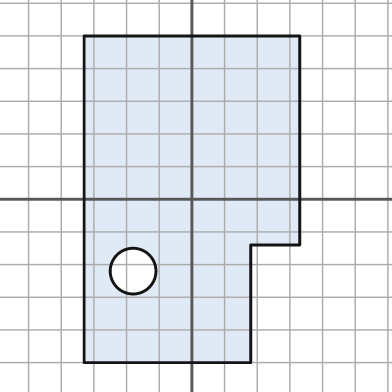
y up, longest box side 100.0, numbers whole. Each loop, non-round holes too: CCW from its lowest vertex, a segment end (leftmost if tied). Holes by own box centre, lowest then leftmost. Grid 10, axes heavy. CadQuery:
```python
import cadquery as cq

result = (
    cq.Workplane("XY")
    .moveTo(-33.0, -50.0)
    .lineTo(18.0, -50.0)
    .lineTo(18.0, -14.0)
    .lineTo(33.0, -14.0)
    .lineTo(33.0, 50.0)
    .lineTo(-33.0, 50.0)
    .close()
    .moveTo(-18.0, -22.0)
    .circle(7.0)
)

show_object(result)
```